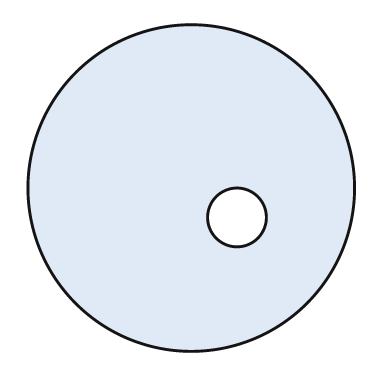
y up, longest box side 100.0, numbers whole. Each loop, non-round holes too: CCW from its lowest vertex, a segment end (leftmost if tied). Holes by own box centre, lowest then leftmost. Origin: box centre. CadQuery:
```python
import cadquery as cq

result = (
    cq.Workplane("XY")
    .moveTo(0.0, 0.0)
    .circle(50.0)
    .moveTo(14.0, -9.0)
    .circle(9.0)
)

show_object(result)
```